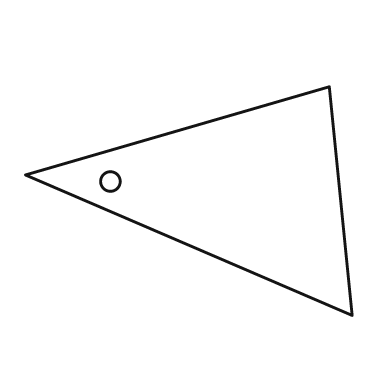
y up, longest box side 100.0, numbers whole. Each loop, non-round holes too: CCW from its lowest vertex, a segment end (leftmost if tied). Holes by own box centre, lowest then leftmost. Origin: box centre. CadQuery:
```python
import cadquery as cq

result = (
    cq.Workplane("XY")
    .moveTo(50.0, -35.0)
    .lineTo(43.0, 35.0)
    .lineTo(-50.0, 8.0)
    .close()
    .moveTo(-24.0, 6.0)
    .circle(3.0)
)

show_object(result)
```